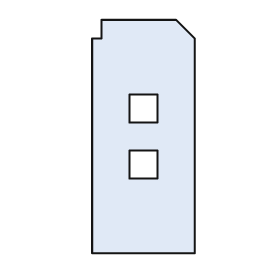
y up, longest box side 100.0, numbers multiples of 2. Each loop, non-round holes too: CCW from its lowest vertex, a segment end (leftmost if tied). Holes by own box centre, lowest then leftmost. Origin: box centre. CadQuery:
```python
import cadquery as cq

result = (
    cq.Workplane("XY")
    .moveTo(-22.0, -50.0)
    .lineTo(22.0, -50.0)
    .lineTo(22.0, 42.0)
    .lineTo(14.0, 50.0)
    .lineTo(-18.0, 50.0)
    .lineTo(-18.0, 42.0)
    .lineTo(-22.0, 42.0)
    .close()
    .moveTo(-6.0, -18.0)
    .lineTo(6.0, -18.0)
    .lineTo(6.0, -6.0)
    .lineTo(-6.0, -6.0)
    .close()
    .moveTo(-6.0, 6.0)
    .lineTo(6.0, 6.0)
    .lineTo(6.0, 18.0)
    .lineTo(-6.0, 18.0)
    .close()
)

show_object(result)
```